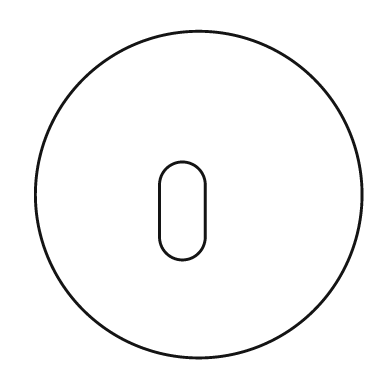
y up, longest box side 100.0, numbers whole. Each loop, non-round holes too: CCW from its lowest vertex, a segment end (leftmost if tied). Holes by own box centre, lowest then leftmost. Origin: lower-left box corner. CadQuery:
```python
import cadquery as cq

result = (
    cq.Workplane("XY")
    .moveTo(50.0, 50.0)
    .circle(50.0)
    .moveTo(38.0, 37.0)
    .threePointArc((45.0, 30.0), (52.0, 37.0))
    .lineTo(52.0, 53.0)
    .threePointArc((45.0, 60.0), (38.0, 53.0))
    .close()
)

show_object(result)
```